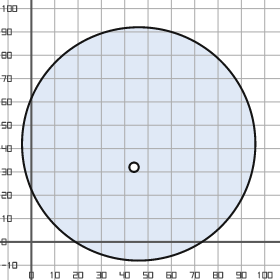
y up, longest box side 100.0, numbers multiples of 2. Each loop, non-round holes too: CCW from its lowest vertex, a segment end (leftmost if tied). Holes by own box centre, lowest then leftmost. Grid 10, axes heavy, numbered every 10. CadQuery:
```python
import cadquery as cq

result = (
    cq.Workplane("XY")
    .moveTo(46.0, 42.0)
    .circle(50.0)
    .moveTo(44.0, 32.0)
    .circle(2.0)
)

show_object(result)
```